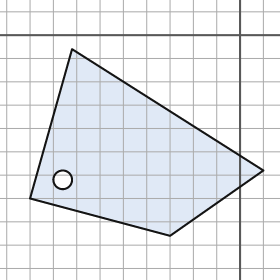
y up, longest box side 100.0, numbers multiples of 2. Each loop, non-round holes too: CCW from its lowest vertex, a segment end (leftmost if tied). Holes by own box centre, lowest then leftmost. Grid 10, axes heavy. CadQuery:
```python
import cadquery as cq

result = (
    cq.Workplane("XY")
    .moveTo(-30.0, -86.0)
    .lineTo(10.0, -58.0)
    .lineTo(-72.0, -6.0)
    .lineTo(-90.0, -70.0)
    .close()
    .moveTo(-76.0, -62.0)
    .circle(4.0)
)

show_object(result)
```